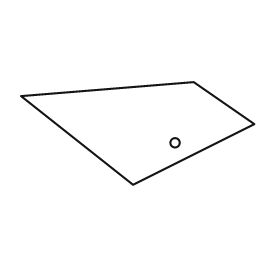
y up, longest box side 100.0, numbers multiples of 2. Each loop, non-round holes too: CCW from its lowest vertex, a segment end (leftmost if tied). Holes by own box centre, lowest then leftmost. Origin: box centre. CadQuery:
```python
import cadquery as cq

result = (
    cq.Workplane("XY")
    .moveTo(-2.0, -22.0)
    .lineTo(50.0, 4.0)
    .lineTo(24.0, 22.0)
    .lineTo(-50.0, 16.0)
    .close()
    .moveTo(16.0, -4.0)
    .circle(2.0)
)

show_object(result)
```